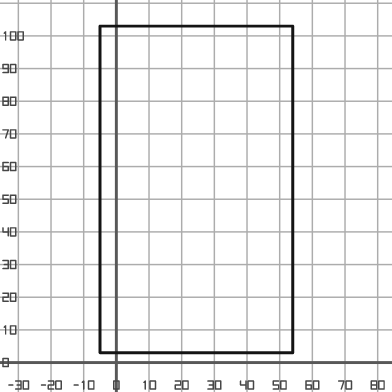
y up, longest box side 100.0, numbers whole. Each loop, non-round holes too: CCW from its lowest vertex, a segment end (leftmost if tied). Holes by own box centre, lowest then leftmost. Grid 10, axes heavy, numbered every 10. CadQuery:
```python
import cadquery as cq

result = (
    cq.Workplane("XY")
    .moveTo(-5.0, 3.0)
    .lineTo(54.0, 3.0)
    .lineTo(54.0, 103.0)
    .lineTo(-5.0, 103.0)
    .close()
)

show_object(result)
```